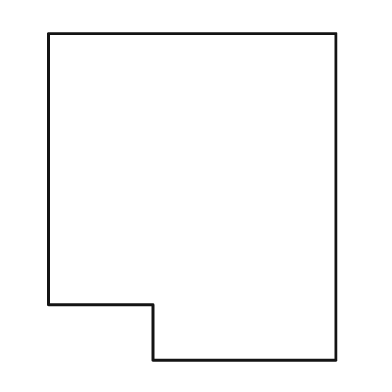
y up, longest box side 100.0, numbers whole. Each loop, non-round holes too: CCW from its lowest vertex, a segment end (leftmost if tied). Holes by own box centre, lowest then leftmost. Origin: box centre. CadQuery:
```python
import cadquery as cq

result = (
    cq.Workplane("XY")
    .moveTo(-12.0, -50.0)
    .lineTo(44.0, -50.0)
    .lineTo(44.0, 50.0)
    .lineTo(-44.0, 50.0)
    .lineTo(-44.0, -33.0)
    .lineTo(-12.0, -33.0)
    .close()
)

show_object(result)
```